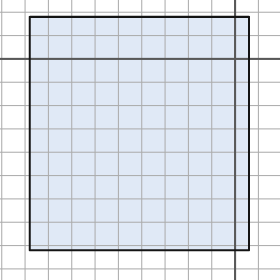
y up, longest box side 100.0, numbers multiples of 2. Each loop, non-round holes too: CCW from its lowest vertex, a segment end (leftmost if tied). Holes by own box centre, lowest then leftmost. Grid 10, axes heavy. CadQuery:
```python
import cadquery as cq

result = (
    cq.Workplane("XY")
    .moveTo(-88.0, -82.0)
    .lineTo(6.0, -82.0)
    .lineTo(6.0, 18.0)
    .lineTo(-88.0, 18.0)
    .close()
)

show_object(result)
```